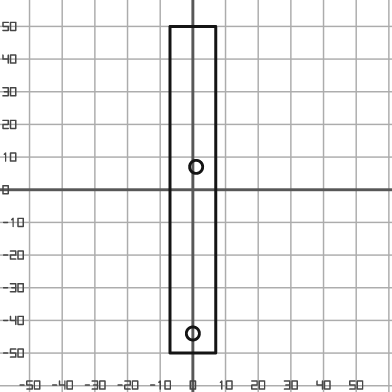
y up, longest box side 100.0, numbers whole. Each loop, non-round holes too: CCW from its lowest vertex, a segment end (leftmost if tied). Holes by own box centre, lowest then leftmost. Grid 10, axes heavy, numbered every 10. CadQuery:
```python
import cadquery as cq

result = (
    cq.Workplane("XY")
    .moveTo(-7.0, -50.0)
    .lineTo(7.0, -50.0)
    .lineTo(7.0, 50.0)
    .lineTo(-7.0, 50.0)
    .close()
    .moveTo(0.0, -44.0)
    .circle(2.0)
    .moveTo(1.0, 7.0)
    .circle(2.0)
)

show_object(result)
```